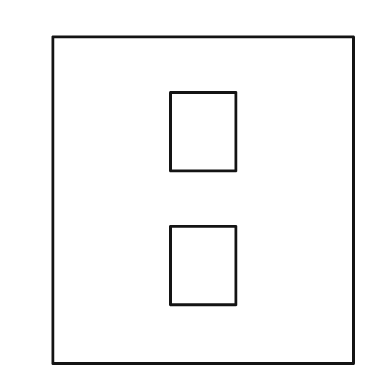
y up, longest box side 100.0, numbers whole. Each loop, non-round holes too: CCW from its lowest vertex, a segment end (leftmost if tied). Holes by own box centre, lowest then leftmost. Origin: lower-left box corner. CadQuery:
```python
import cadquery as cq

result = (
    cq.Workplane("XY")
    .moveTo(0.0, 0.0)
    .lineTo(92.0, 0.0)
    .lineTo(92.0, 100.0)
    .lineTo(0.0, 100.0)
    .close()
    .moveTo(36.0, 18.0)
    .lineTo(56.0, 18.0)
    .lineTo(56.0, 42.0)
    .lineTo(36.0, 42.0)
    .close()
    .moveTo(36.0, 59.0)
    .lineTo(56.0, 59.0)
    .lineTo(56.0, 83.0)
    .lineTo(36.0, 83.0)
    .close()
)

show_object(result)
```